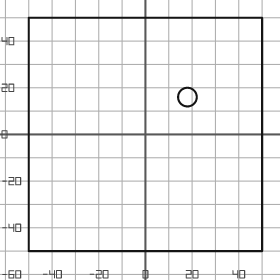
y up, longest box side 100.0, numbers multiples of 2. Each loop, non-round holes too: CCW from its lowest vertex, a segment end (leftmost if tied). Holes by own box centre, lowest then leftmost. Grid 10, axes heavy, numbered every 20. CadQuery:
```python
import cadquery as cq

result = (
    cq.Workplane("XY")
    .moveTo(-50.0, -50.0)
    .lineTo(50.0, -50.0)
    .lineTo(50.0, 50.0)
    .lineTo(-50.0, 50.0)
    .close()
    .moveTo(18.0, 16.0)
    .circle(4.0)
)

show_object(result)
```